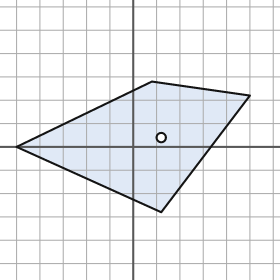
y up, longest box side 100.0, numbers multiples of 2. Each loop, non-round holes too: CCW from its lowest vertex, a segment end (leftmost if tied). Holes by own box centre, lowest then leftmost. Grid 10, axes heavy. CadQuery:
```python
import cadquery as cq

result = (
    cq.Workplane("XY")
    .moveTo(12.0, -28.0)
    .lineTo(50.0, 22.0)
    .lineTo(8.0, 28.0)
    .lineTo(-50.0, 0.0)
    .close()
    .moveTo(12.0, 4.0)
    .circle(2.0)
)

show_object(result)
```